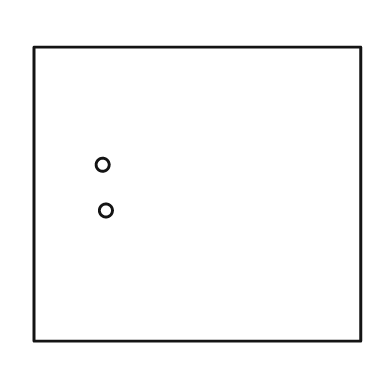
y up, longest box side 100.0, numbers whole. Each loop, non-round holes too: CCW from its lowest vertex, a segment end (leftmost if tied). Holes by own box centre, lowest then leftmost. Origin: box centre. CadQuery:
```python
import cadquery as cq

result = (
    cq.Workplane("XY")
    .moveTo(-50.0, -45.0)
    .lineTo(50.0, -45.0)
    .lineTo(50.0, 45.0)
    .lineTo(-50.0, 45.0)
    .close()
    .moveTo(-28.0, -5.0)
    .circle(2.0)
    .moveTo(-29.0, 9.0)
    .circle(2.0)
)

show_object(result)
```